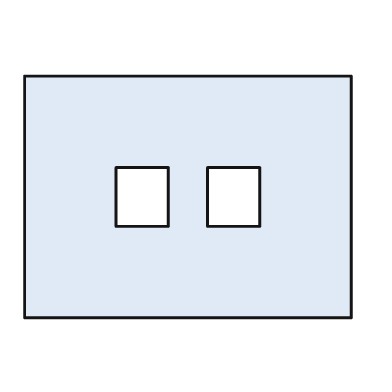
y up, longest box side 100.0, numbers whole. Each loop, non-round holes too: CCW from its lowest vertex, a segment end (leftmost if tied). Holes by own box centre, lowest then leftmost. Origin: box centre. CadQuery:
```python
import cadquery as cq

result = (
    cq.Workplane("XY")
    .moveTo(-50.0, -37.0)
    .lineTo(50.0, -37.0)
    .lineTo(50.0, 37.0)
    .lineTo(-50.0, 37.0)
    .close()
    .moveTo(-22.0, -9.0)
    .lineTo(-6.0, -9.0)
    .lineTo(-6.0, 9.0)
    .lineTo(-22.0, 9.0)
    .close()
    .moveTo(6.0, -9.0)
    .lineTo(22.0, -9.0)
    .lineTo(22.0, 9.0)
    .lineTo(6.0, 9.0)
    .close()
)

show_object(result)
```